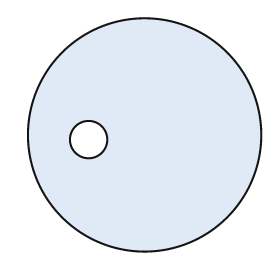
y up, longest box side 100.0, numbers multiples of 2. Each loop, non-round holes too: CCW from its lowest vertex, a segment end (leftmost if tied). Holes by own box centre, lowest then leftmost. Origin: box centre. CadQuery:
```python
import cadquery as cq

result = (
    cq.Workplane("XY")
    .moveTo(0.0, 0.0)
    .circle(50.0)
    .moveTo(-24.0, -2.0)
    .circle(8.0)
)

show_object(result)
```